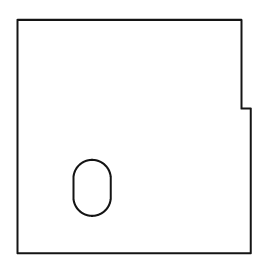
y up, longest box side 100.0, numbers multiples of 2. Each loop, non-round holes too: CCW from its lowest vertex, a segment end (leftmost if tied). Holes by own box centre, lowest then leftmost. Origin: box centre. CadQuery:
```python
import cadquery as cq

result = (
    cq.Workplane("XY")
    .moveTo(-50.0, -50.0)
    .lineTo(50.0, -50.0)
    .lineTo(50.0, 12.0)
    .lineTo(46.0, 12.0)
    .lineTo(46.0, 50.0)
    .lineTo(-50.0, 50.0)
    .close()
    .moveTo(-26.0, -26.0)
    .threePointArc((-18.0, -34.0), (-10.0, -26.0))
    .lineTo(-10.0, -18.0)
    .threePointArc((-18.0, -10.0), (-26.0, -18.0))
    .close()
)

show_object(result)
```